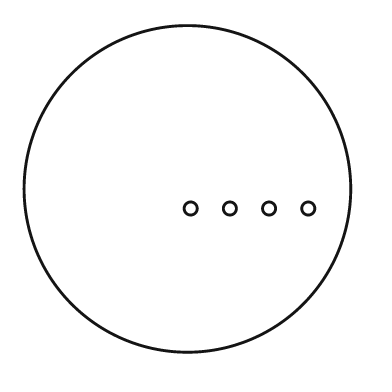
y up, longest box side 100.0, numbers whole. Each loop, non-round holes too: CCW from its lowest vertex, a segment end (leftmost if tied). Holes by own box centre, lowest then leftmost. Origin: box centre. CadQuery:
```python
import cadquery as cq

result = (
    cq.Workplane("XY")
    .moveTo(0.0, 0.0)
    .circle(50.0)
    .moveTo(1.0, -6.0)
    .circle(2.0)
    .moveTo(13.0, -6.0)
    .circle(2.0)
    .moveTo(25.0, -6.0)
    .circle(2.0)
    .moveTo(37.0, -6.0)
    .circle(2.0)
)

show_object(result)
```